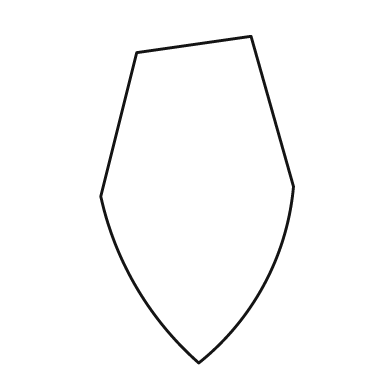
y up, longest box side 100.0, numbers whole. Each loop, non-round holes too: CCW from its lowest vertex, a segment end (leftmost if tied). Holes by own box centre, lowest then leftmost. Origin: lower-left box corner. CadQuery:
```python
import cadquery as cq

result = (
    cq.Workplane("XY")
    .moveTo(30.0, 0.0)
    .threePointArc((50.0, 24.0), (59.0, 54.0))
    .lineTo(46.0, 100.0)
    .lineTo(11.0, 95.0)
    .lineTo(0.0, 51.0)
    .threePointArc((11.0, 23.0), (30.0, 0.0))
    .close()
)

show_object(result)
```